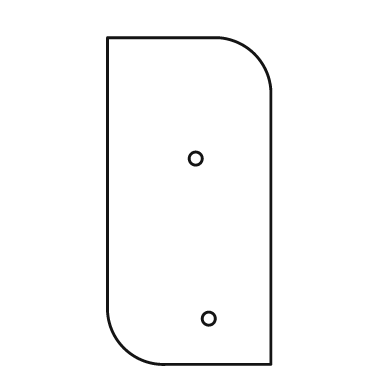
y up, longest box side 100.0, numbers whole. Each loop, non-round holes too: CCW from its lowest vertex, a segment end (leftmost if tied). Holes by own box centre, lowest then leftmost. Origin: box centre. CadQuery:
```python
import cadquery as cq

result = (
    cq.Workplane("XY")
    .moveTo(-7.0, -50.0)
    .lineTo(25.0, -50.0)
    .lineTo(25.0, 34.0)
    .threePointArc((20.0, 45.0), (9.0, 50.0))
    .lineTo(-25.0, 50.0)
    .lineTo(-25.0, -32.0)
    .threePointArc((-20.0, -45.0), (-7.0, -50.0))
    .close()
    .moveTo(6.0, -36.0)
    .circle(2.0)
    .moveTo(2.0, 13.0)
    .circle(2.0)
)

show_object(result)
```